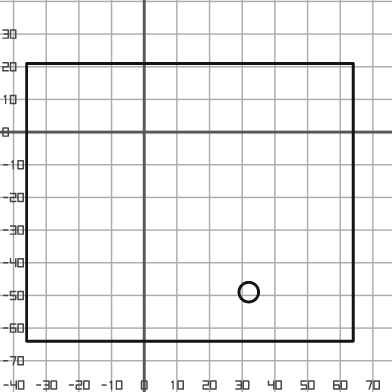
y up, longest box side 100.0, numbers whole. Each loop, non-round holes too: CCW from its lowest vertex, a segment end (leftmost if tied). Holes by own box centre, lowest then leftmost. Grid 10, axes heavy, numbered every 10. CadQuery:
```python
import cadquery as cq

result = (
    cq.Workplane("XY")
    .moveTo(-36.0, -64.0)
    .lineTo(64.0, -64.0)
    .lineTo(64.0, 21.0)
    .lineTo(-36.0, 21.0)
    .close()
    .moveTo(32.0, -49.0)
    .circle(3.0)
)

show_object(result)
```